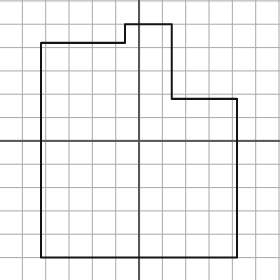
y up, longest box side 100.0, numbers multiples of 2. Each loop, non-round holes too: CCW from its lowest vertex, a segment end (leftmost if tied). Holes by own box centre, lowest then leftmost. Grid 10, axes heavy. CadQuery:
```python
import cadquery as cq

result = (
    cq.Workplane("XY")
    .moveTo(-42.0, -50.0)
    .lineTo(42.0, -50.0)
    .lineTo(42.0, 18.0)
    .lineTo(14.0, 18.0)
    .lineTo(14.0, 50.0)
    .lineTo(-6.0, 50.0)
    .lineTo(-6.0, 42.0)
    .lineTo(-42.0, 42.0)
    .close()
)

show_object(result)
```